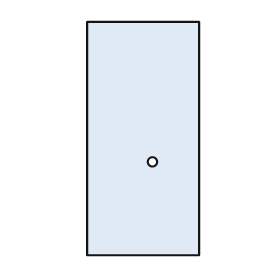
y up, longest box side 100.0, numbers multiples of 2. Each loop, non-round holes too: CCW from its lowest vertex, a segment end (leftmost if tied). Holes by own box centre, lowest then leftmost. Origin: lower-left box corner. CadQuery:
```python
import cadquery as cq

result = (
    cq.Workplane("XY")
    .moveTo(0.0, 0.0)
    .lineTo(48.0, 0.0)
    .lineTo(48.0, 100.0)
    .lineTo(0.0, 100.0)
    .close()
    .moveTo(28.0, 40.0)
    .circle(2.0)
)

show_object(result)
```